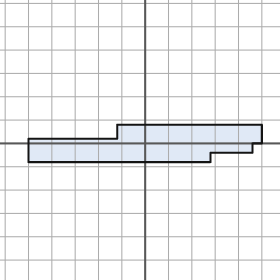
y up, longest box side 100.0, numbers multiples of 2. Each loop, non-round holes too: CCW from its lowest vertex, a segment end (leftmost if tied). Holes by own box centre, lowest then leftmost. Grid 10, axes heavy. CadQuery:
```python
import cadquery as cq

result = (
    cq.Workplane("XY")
    .moveTo(-50.0, -8.0)
    .lineTo(28.0, -8.0)
    .lineTo(28.0, -4.0)
    .lineTo(46.0, -4.0)
    .lineTo(46.0, 0.0)
    .lineTo(50.0, 0.0)
    .lineTo(50.0, 8.0)
    .lineTo(-12.0, 8.0)
    .lineTo(-12.0, 2.0)
    .lineTo(-50.0, 2.0)
    .close()
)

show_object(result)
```